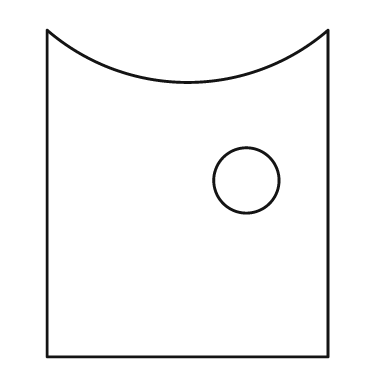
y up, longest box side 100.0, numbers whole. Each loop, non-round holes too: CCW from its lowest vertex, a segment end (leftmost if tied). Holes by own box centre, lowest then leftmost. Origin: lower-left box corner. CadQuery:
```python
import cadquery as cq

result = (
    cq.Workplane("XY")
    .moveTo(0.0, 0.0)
    .lineTo(86.0, 0.0)
    .lineTo(86.0, 100.0)
    .threePointArc((43.0, 84.0), (0.0, 100.0))
    .close()
    .moveTo(61.0, 54.0)
    .circle(10.0)
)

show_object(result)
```